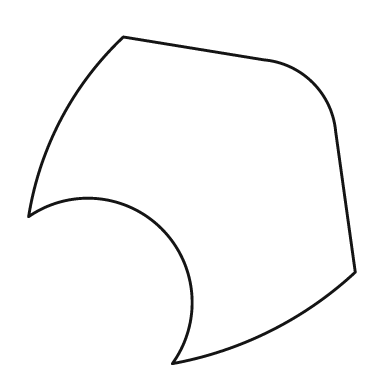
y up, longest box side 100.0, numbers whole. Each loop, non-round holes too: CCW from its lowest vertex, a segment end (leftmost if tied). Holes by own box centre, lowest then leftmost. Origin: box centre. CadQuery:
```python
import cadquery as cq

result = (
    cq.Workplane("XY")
    .moveTo(-6.0, -50.0)
    .threePointArc((24.0, -40.0), (50.0, -22.0))
    .lineTo(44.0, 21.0)
    .threePointArc((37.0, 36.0), (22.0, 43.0))
    .lineTo(-21.0, 50.0)
    .threePointArc((-40.0, 25.0), (-50.0, -5.0))
    .threePointArc((-9.0, -9.0), (-6.0, -50.0))
    .close()
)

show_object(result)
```